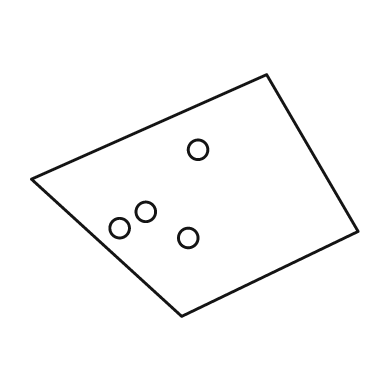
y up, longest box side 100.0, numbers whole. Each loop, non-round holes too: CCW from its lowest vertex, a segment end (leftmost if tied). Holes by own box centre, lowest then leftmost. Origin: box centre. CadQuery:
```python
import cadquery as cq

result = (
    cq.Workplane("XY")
    .moveTo(-4.0, -37.0)
    .lineTo(50.0, -11.0)
    .lineTo(22.0, 37.0)
    .lineTo(-50.0, 5.0)
    .close()
    .moveTo(-2.0, -13.0)
    .circle(3.0)
    .moveTo(-23.0, -10.0)
    .circle(3.0)
    .moveTo(-15.0, -5.0)
    .circle(3.0)
    .moveTo(1.0, 14.0)
    .circle(3.0)
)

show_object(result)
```